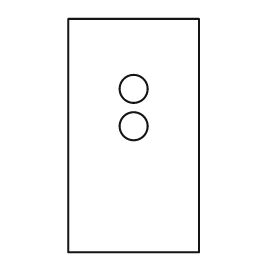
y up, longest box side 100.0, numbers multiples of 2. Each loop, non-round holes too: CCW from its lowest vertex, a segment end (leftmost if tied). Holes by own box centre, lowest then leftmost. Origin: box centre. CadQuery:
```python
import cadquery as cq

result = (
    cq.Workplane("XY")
    .moveTo(-28.0, -50.0)
    .lineTo(28.0, -50.0)
    .lineTo(28.0, 50.0)
    .lineTo(-28.0, 50.0)
    .close()
    .moveTo(0.0, 4.0)
    .circle(6.0)
    .moveTo(0.0, 20.0)
    .circle(6.0)
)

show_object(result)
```